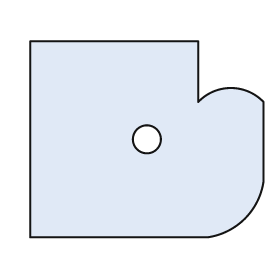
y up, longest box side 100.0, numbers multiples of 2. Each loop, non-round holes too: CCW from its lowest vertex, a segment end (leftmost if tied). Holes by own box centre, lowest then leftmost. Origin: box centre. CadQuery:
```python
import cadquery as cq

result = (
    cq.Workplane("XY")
    .moveTo(-50.0, -42.0)
    .lineTo(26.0, -42.0)
    .threePointArc((42.0, -34.0), (50.0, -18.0))
    .lineTo(50.0, 16.0)
    .threePointArc((36.0, 22.0), (22.0, 16.0))
    .lineTo(22.0, 42.0)
    .lineTo(-50.0, 42.0)
    .close()
    .moveTo(0.0, 0.0)
    .circle(6.0)
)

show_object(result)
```